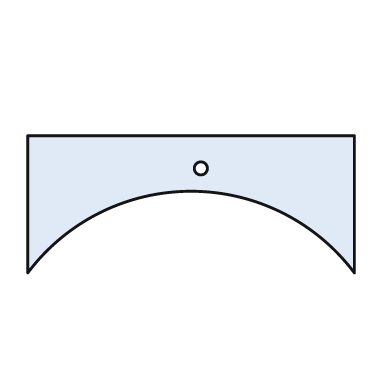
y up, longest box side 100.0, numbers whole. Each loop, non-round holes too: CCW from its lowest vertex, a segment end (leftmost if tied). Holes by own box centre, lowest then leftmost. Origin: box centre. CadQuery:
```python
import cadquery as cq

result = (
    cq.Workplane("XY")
    .moveTo(-50.0, -21.0)
    .threePointArc((0.0, 4.0), (50.0, -21.0))
    .lineTo(50.0, 21.0)
    .lineTo(-50.0, 21.0)
    .close()
    .moveTo(3.0, 11.0)
    .circle(2.0)
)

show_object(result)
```